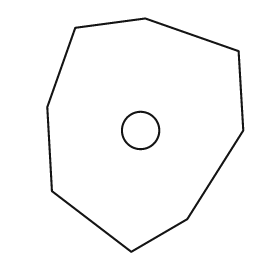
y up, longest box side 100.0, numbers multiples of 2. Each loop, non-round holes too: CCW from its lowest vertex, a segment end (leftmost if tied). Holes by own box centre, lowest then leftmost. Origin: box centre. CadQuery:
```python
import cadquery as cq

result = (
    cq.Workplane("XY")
    .moveTo(-6.0, -50.0)
    .lineTo(18.0, -36.0)
    .lineTo(42.0, 2.0)
    .lineTo(40.0, 36.0)
    .lineTo(0.0, 50.0)
    .lineTo(-30.0, 46.0)
    .lineTo(-42.0, 12.0)
    .lineTo(-40.0, -24.0)
    .close()
    .moveTo(-2.0, 2.0)
    .circle(8.0)
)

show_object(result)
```